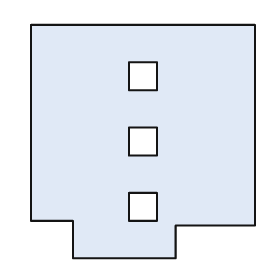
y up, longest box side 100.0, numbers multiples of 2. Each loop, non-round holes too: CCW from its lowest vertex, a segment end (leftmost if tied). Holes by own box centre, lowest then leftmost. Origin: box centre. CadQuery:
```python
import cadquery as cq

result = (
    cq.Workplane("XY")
    .moveTo(-30.0, -50.0)
    .lineTo(14.0, -50.0)
    .lineTo(14.0, -36.0)
    .lineTo(48.0, -36.0)
    .lineTo(48.0, 50.0)
    .lineTo(-48.0, 50.0)
    .lineTo(-48.0, -34.0)
    .lineTo(-30.0, -34.0)
    .close()
    .moveTo(-6.0, -34.0)
    .lineTo(6.0, -34.0)
    .lineTo(6.0, -22.0)
    .lineTo(-6.0, -22.0)
    .close()
    .moveTo(-6.0, -6.0)
    .lineTo(6.0, -6.0)
    .lineTo(6.0, 6.0)
    .lineTo(-6.0, 6.0)
    .close()
    .moveTo(-6.0, 22.0)
    .lineTo(6.0, 22.0)
    .lineTo(6.0, 34.0)
    .lineTo(-6.0, 34.0)
    .close()
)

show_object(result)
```